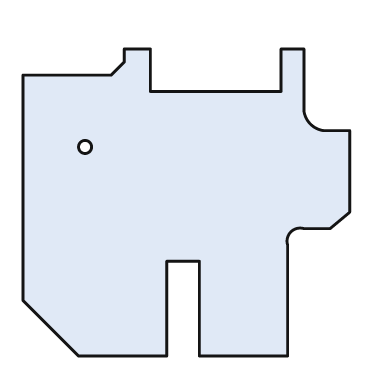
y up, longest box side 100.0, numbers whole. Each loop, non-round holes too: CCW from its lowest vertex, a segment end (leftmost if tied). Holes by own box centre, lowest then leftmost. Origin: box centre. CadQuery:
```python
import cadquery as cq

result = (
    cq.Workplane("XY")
    .moveTo(-33.0, -47.0)
    .lineTo(-6.0, -47.0)
    .lineTo(-6.0, -18.0)
    .lineTo(4.0, -18.0)
    .lineTo(4.0, -47.0)
    .lineTo(31.0, -47.0)
    .lineTo(31.0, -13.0)
    .threePointArc((32.0, -9.0), (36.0, -8.0))
    .lineTo(44.0, -8.0)
    .lineTo(50.0, -3.0)
    .lineTo(50.0, 22.0)
    .lineTo(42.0, 22.0)
    .threePointArc((38.0, 24.0), (36.0, 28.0))
    .lineTo(36.0, 47.0)
    .lineTo(29.0, 47.0)
    .lineTo(29.0, 34.0)
    .lineTo(-11.0, 34.0)
    .lineTo(-11.0, 47.0)
    .lineTo(-19.0, 47.0)
    .lineTo(-19.0, 43.0)
    .lineTo(-23.0, 39.0)
    .lineTo(-50.0, 39.0)
    .lineTo(-50.0, -30.0)
    .close()
    .moveTo(-31.0, 17.0)
    .circle(2.0)
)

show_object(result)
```